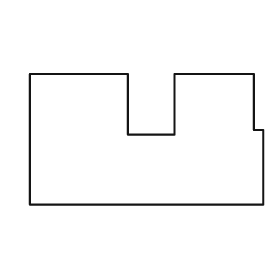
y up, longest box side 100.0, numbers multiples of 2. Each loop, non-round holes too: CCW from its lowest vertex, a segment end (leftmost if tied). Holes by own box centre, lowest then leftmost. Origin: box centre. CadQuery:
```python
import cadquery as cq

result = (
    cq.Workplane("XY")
    .moveTo(-50.0, -28.0)
    .lineTo(50.0, -28.0)
    .lineTo(50.0, 4.0)
    .lineTo(46.0, 4.0)
    .lineTo(46.0, 28.0)
    .lineTo(12.0, 28.0)
    .lineTo(12.0, 2.0)
    .lineTo(-8.0, 2.0)
    .lineTo(-8.0, 28.0)
    .lineTo(-50.0, 28.0)
    .close()
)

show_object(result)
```